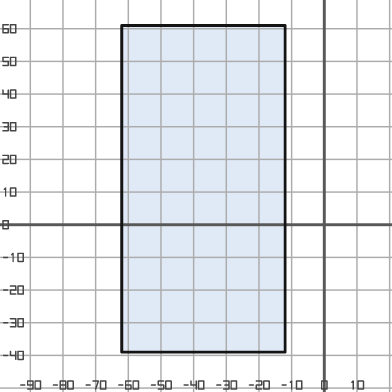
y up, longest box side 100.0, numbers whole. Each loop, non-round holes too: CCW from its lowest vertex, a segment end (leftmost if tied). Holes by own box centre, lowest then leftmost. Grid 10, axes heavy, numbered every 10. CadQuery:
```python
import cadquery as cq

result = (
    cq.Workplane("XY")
    .moveTo(-62.0, -39.0)
    .lineTo(-12.0, -39.0)
    .lineTo(-12.0, 61.0)
    .lineTo(-62.0, 61.0)
    .close()
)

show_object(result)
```